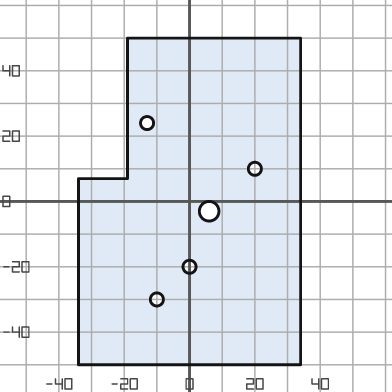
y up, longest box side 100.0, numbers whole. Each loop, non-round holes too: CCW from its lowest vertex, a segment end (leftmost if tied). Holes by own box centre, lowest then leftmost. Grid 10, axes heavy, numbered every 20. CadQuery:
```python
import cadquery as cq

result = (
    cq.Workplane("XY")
    .moveTo(-34.0, -50.0)
    .lineTo(34.0, -50.0)
    .lineTo(34.0, 50.0)
    .lineTo(-19.0, 50.0)
    .lineTo(-19.0, 7.0)
    .lineTo(-34.0, 7.0)
    .close()
    .moveTo(-10.0, -30.0)
    .circle(2.0)
    .moveTo(0.0, -20.0)
    .circle(2.0)
    .moveTo(6.0, -3.0)
    .circle(3.0)
    .moveTo(20.0, 10.0)
    .circle(2.0)
    .moveTo(-13.0, 24.0)
    .circle(2.0)
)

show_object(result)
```